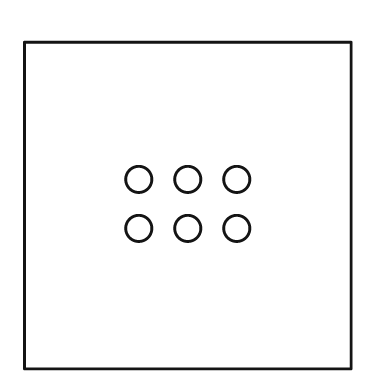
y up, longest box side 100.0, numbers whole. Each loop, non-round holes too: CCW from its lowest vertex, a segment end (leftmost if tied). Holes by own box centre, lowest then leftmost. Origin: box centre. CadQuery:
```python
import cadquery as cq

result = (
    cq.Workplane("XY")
    .moveTo(-50.0, -50.0)
    .lineTo(50.0, -50.0)
    .lineTo(50.0, 50.0)
    .lineTo(-50.0, 50.0)
    .close()
    .moveTo(-15.0, -7.0)
    .circle(4.0)
    .moveTo(0.0, -7.0)
    .circle(4.0)
    .moveTo(15.0, -7.0)
    .circle(4.0)
    .moveTo(-15.0, 8.0)
    .circle(4.0)
    .moveTo(0.0, 8.0)
    .circle(4.0)
    .moveTo(15.0, 8.0)
    .circle(4.0)
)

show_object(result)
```